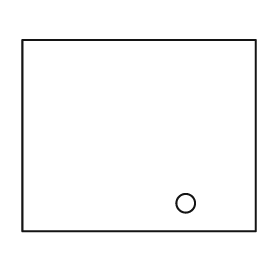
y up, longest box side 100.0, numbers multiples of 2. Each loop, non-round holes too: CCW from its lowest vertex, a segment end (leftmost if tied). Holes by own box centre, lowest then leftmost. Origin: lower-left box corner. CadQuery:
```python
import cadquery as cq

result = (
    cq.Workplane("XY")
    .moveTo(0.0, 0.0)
    .lineTo(100.0, 0.0)
    .lineTo(100.0, 82.0)
    .lineTo(0.0, 82.0)
    .close()
    .moveTo(70.0, 12.0)
    .circle(4.0)
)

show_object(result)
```